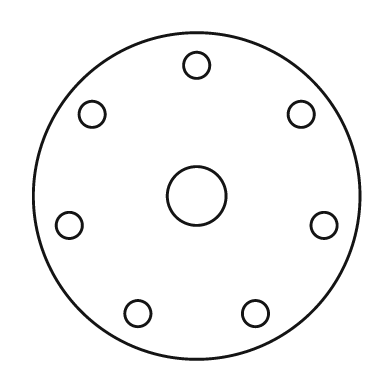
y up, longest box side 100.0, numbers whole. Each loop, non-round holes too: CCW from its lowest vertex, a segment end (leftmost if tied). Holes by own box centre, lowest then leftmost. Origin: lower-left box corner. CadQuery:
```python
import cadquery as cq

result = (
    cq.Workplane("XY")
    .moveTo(50.0, 50.0)
    .circle(50.0)
    .moveTo(32.0, 14.0)
    .circle(4.0)
    .moveTo(68.0, 14.0)
    .circle(4.0)
    .moveTo(11.0, 41.0)
    .circle(4.0)
    .moveTo(89.0, 41.0)
    .circle(4.0)
    .moveTo(50.0, 50.0)
    .circle(9.0)
    .moveTo(18.0, 75.0)
    .circle(4.0)
    .moveTo(82.0, 75.0)
    .circle(4.0)
    .moveTo(50.0, 90.0)
    .circle(4.0)
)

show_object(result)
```